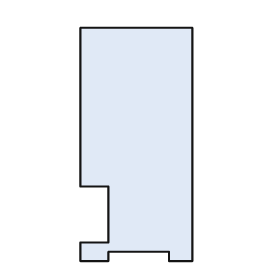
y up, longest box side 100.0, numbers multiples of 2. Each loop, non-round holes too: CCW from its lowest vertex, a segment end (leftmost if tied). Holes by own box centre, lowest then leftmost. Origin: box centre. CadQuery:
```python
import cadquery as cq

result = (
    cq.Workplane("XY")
    .moveTo(-24.0, -50.0)
    .lineTo(-12.0, -50.0)
    .lineTo(-12.0, -46.0)
    .lineTo(14.0, -46.0)
    .lineTo(14.0, -50.0)
    .lineTo(24.0, -50.0)
    .lineTo(24.0, 50.0)
    .lineTo(-24.0, 50.0)
    .lineTo(-24.0, -18.0)
    .lineTo(-12.0, -18.0)
    .lineTo(-12.0, -42.0)
    .lineTo(-24.0, -42.0)
    .close()
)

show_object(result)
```